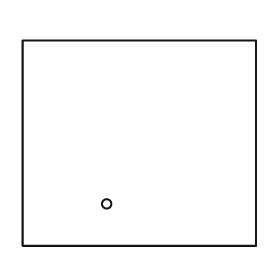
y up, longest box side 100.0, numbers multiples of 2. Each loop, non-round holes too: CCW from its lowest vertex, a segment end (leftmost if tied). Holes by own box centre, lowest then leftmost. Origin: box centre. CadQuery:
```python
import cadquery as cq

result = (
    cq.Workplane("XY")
    .moveTo(-50.0, -44.0)
    .lineTo(50.0, -44.0)
    .lineTo(50.0, 44.0)
    .lineTo(-50.0, 44.0)
    .close()
    .moveTo(-14.0, -26.0)
    .circle(2.0)
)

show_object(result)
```